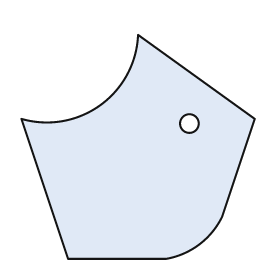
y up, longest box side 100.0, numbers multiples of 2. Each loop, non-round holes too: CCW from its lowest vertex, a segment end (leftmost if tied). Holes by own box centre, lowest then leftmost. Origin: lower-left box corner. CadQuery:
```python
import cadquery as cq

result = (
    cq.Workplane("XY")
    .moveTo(20.0, 0.0)
    .lineTo(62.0, 0.0)
    .threePointArc((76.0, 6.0), (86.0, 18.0))
    .lineTo(100.0, 60.0)
    .lineTo(50.0, 96.0)
    .threePointArc((34.0, 66.0), (0.0, 60.0))
    .close()
    .moveTo(72.0, 58.0)
    .circle(4.0)
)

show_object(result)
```